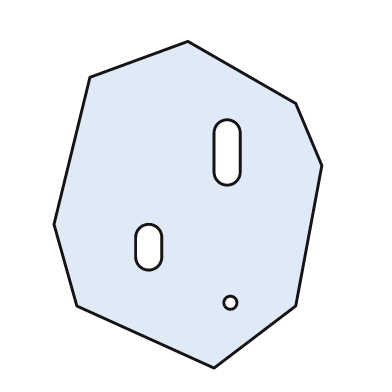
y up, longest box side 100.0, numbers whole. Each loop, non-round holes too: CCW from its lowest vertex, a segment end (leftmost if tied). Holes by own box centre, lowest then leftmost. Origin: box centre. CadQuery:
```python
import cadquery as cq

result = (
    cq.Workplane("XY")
    .moveTo(8.0, -50.0)
    .lineTo(33.0, -31.0)
    .lineTo(41.0, 12.0)
    .lineTo(33.0, 31.0)
    .lineTo(0.0, 50.0)
    .lineTo(-30.0, 39.0)
    .lineTo(-41.0, -6.0)
    .lineTo(-34.0, -31.0)
    .close()
    .moveTo(13.0, -30.0)
    .circle(2.0)
    .moveTo(-16.0, -16.0)
    .threePointArc((-12.0, -20.0), (-8.0, -16.0))
    .lineTo(-8.0, -10.0)
    .threePointArc((-12.0, -6.0), (-16.0, -10.0))
    .close()
    .moveTo(8.0, 10.0)
    .threePointArc((12.0, 6.0), (16.0, 10.0))
    .lineTo(16.0, 22.0)
    .threePointArc((12.0, 26.0), (8.0, 22.0))
    .close()
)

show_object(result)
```